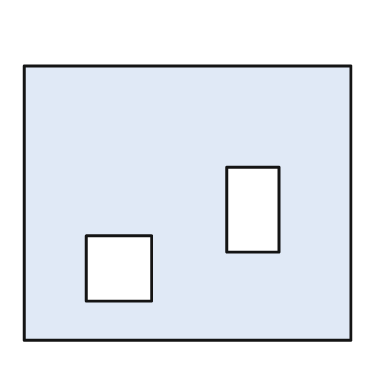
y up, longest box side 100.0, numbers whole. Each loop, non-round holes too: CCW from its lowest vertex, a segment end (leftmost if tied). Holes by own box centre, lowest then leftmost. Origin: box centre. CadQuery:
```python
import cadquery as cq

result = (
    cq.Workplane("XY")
    .moveTo(-50.0, -42.0)
    .lineTo(50.0, -42.0)
    .lineTo(50.0, 42.0)
    .lineTo(-50.0, 42.0)
    .close()
    .moveTo(-31.0, -30.0)
    .lineTo(-11.0, -30.0)
    .lineTo(-11.0, -10.0)
    .lineTo(-31.0, -10.0)
    .close()
    .moveTo(12.0, -15.0)
    .lineTo(28.0, -15.0)
    .lineTo(28.0, 11.0)
    .lineTo(12.0, 11.0)
    .close()
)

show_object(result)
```